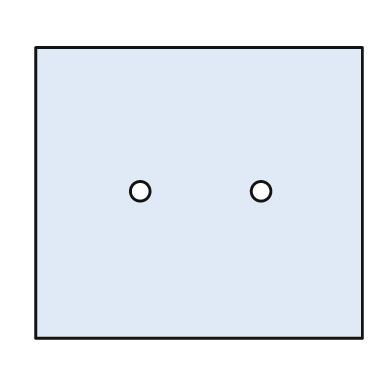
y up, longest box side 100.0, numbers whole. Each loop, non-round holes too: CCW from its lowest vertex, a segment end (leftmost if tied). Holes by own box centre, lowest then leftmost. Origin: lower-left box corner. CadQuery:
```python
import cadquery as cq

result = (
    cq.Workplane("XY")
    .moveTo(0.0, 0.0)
    .lineTo(100.0, 0.0)
    .lineTo(100.0, 89.0)
    .lineTo(0.0, 89.0)
    .close()
    .moveTo(32.0, 45.0)
    .circle(3.0)
    .moveTo(69.0, 45.0)
    .circle(3.0)
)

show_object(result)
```